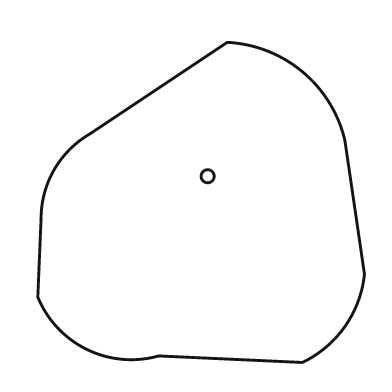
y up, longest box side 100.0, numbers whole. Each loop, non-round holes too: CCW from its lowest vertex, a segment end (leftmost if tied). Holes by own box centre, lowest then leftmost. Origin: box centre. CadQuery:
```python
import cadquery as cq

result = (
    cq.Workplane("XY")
    .moveTo(31.0, -49.0)
    .threePointArc((44.0, -38.0), (50.0, -22.0))
    .lineTo(44.0, 19.0)
    .threePointArc((31.0, 40.0), (8.0, 49.0))
    .lineTo(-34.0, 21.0)
    .threePointArc((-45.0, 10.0), (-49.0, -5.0))
    .lineTo(-50.0, -29.0)
    .threePointArc((-35.0, -45.0), (-13.0, -47.0))
    .close()
    .moveTo(2.0, 8.0)
    .circle(2.0)
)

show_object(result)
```